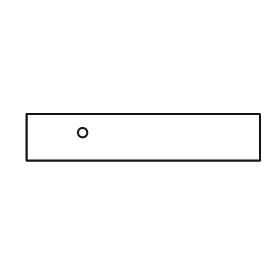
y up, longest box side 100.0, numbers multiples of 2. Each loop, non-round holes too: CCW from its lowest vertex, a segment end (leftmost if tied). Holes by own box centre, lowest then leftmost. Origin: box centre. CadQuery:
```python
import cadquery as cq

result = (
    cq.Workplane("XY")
    .moveTo(-50.0, -10.0)
    .lineTo(50.0, -10.0)
    .lineTo(50.0, 10.0)
    .lineTo(-50.0, 10.0)
    .close()
    .moveTo(-26.0, 2.0)
    .circle(2.0)
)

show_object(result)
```